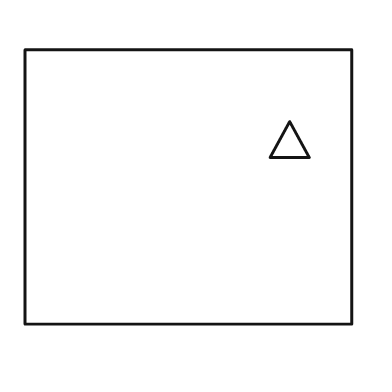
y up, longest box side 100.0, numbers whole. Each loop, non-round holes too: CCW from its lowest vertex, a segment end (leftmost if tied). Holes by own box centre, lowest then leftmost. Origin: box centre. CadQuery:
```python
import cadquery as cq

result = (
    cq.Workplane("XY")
    .moveTo(-50.0, -42.0)
    .lineTo(50.0, -42.0)
    .lineTo(50.0, 42.0)
    .lineTo(-50.0, 42.0)
    .close()
    .moveTo(25.0, 9.0)
    .lineTo(37.0, 9.0)
    .lineTo(31.0, 20.0)
    .close()
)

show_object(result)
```